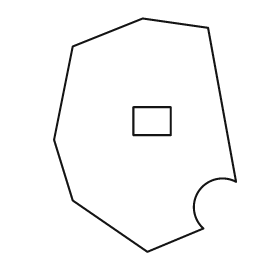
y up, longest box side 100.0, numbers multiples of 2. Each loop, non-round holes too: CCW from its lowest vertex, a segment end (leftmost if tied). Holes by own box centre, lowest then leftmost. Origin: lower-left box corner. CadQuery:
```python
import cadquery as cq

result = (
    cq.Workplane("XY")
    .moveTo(40.0, 0.0)
    .lineTo(64.0, 10.0)
    .threePointArc((62.0, 26.0), (78.0, 30.0))
    .lineTo(66.0, 96.0)
    .lineTo(38.0, 100.0)
    .lineTo(8.0, 88.0)
    .lineTo(0.0, 48.0)
    .lineTo(8.0, 22.0)
    .close()
    .moveTo(34.0, 50.0)
    .lineTo(50.0, 50.0)
    .lineTo(50.0, 62.0)
    .lineTo(34.0, 62.0)
    .close()
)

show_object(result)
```